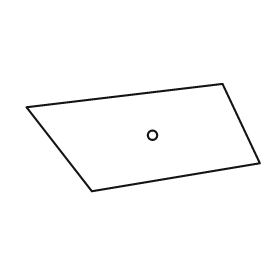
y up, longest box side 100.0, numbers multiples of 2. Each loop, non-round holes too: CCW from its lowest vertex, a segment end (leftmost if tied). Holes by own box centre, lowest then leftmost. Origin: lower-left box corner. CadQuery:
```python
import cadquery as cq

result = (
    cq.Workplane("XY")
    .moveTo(28.0, 0.0)
    .lineTo(100.0, 12.0)
    .lineTo(84.0, 46.0)
    .lineTo(0.0, 36.0)
    .close()
    .moveTo(54.0, 24.0)
    .circle(2.0)
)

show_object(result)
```